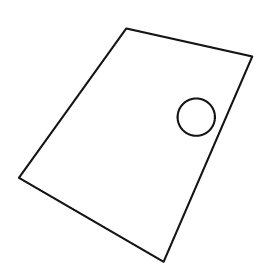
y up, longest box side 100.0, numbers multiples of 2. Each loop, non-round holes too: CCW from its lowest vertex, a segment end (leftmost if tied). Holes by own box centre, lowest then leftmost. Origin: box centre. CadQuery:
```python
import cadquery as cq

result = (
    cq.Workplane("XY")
    .moveTo(12.0, -50.0)
    .lineTo(50.0, 38.0)
    .lineTo(-4.0, 50.0)
    .lineTo(-50.0, -14.0)
    .close()
    .moveTo(26.0, 12.0)
    .circle(8.0)
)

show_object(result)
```